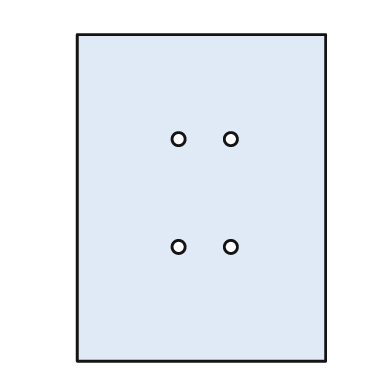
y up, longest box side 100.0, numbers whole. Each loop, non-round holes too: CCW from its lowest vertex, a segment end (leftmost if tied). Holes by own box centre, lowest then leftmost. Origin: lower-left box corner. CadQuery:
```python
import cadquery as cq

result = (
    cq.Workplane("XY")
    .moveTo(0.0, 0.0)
    .lineTo(76.0, 0.0)
    .lineTo(76.0, 100.0)
    .lineTo(0.0, 100.0)
    .close()
    .moveTo(31.0, 35.0)
    .circle(2.0)
    .moveTo(47.0, 35.0)
    .circle(2.0)
    .moveTo(31.0, 68.0)
    .circle(2.0)
    .moveTo(47.0, 68.0)
    .circle(2.0)
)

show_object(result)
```